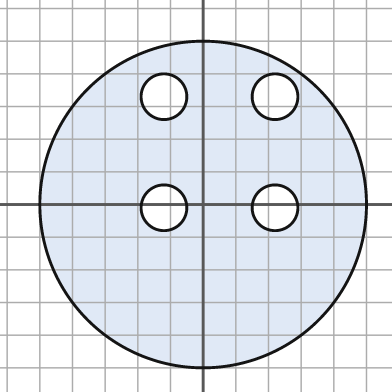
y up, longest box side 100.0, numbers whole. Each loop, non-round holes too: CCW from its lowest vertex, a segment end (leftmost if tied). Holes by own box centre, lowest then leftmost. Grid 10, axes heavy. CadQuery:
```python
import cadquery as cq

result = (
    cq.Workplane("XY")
    .moveTo(0.0, 0.0)
    .circle(50.0)
    .moveTo(-12.0, -1.0)
    .circle(7.0)
    .moveTo(22.0, -1.0)
    .circle(7.0)
    .moveTo(-12.0, 33.0)
    .circle(7.0)
    .moveTo(22.0, 33.0)
    .circle(7.0)
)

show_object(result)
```